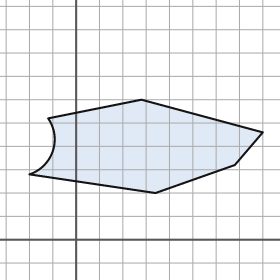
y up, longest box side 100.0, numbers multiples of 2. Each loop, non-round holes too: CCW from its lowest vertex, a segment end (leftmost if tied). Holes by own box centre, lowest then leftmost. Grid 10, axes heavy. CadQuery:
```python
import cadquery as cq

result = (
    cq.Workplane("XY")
    .moveTo(34.0, 20.0)
    .lineTo(68.0, 32.0)
    .lineTo(80.0, 46.0)
    .lineTo(28.0, 60.0)
    .lineTo(-12.0, 52.0)
    .threePointArc((-10.0, 38.0), (-20.0, 28.0))
    .close()
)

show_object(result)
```